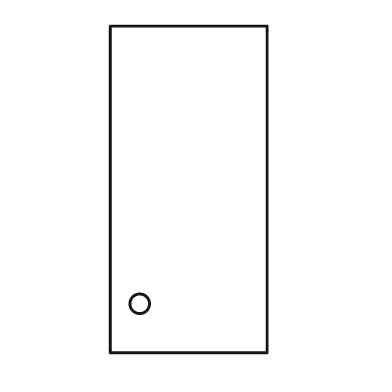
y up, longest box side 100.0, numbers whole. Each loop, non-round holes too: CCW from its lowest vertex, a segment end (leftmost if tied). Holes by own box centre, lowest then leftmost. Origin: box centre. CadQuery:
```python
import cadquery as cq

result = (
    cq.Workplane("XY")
    .moveTo(-24.0, -50.0)
    .lineTo(24.0, -50.0)
    .lineTo(24.0, 50.0)
    .lineTo(-24.0, 50.0)
    .close()
    .moveTo(-15.0, -35.0)
    .circle(3.0)
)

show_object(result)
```